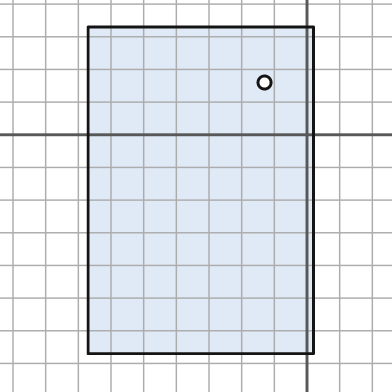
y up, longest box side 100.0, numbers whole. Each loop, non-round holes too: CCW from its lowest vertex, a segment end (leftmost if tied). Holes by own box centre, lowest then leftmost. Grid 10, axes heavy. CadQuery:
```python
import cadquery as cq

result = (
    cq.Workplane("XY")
    .moveTo(-67.0, -67.0)
    .lineTo(2.0, -67.0)
    .lineTo(2.0, 33.0)
    .lineTo(-67.0, 33.0)
    .close()
    .moveTo(-13.0, 16.0)
    .circle(2.0)
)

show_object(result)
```